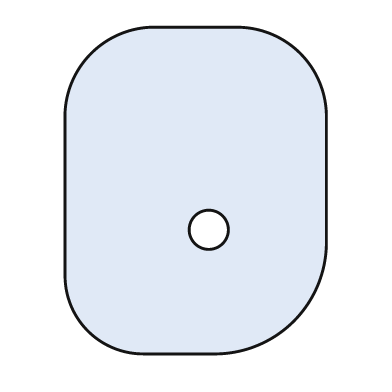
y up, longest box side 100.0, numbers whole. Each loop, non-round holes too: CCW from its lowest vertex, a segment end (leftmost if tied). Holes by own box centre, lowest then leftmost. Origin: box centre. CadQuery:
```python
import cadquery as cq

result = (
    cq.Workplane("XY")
    .moveTo(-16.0, -50.0)
    .lineTo(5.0, -50.0)
    .threePointArc((30.0, -40.0), (40.0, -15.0))
    .lineTo(40.0, 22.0)
    .threePointArc((32.0, 42.0), (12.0, 50.0))
    .lineTo(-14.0, 50.0)
    .threePointArc((-32.0, 42.0), (-40.0, 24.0))
    .lineTo(-40.0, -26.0)
    .threePointArc((-33.0, -43.0), (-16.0, -50.0))
    .close()
    .moveTo(4.0, -12.0)
    .circle(6.0)
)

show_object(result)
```